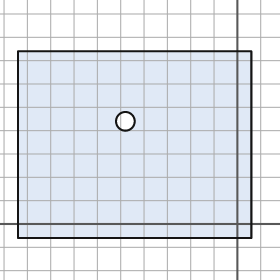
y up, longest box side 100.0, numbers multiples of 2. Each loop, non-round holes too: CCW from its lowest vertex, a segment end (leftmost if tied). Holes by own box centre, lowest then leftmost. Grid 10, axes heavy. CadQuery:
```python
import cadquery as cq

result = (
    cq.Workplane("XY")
    .moveTo(-94.0, -6.0)
    .lineTo(6.0, -6.0)
    .lineTo(6.0, 74.0)
    .lineTo(-94.0, 74.0)
    .close()
    .moveTo(-48.0, 44.0)
    .circle(4.0)
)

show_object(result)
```